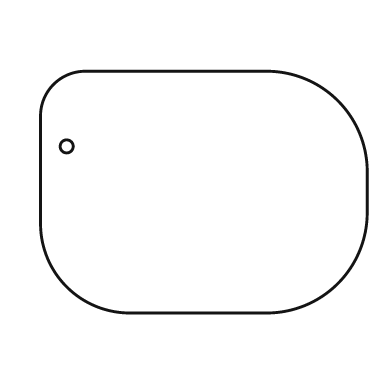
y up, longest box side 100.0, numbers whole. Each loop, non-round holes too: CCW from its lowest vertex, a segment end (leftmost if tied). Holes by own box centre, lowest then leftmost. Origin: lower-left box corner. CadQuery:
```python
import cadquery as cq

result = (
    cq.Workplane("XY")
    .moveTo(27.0, 0.0)
    .lineTo(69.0, 0.0)
    .threePointArc((91.0, 9.0), (100.0, 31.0))
    .lineTo(100.0, 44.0)
    .threePointArc((91.0, 65.0), (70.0, 74.0))
    .lineTo(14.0, 74.0)
    .threePointArc((4.0, 70.0), (0.0, 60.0))
    .lineTo(0.0, 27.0)
    .threePointArc((8.0, 8.0), (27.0, 0.0))
    .close()
    .moveTo(8.0, 51.0)
    .circle(2.0)
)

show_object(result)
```